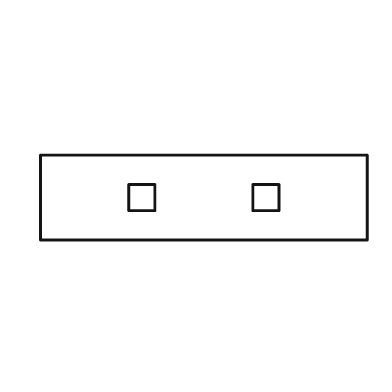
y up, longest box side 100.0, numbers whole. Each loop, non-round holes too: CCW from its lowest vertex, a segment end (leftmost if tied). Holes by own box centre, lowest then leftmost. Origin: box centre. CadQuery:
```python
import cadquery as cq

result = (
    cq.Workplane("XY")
    .moveTo(-50.0, -13.0)
    .lineTo(50.0, -13.0)
    .lineTo(50.0, 13.0)
    .lineTo(-50.0, 13.0)
    .close()
    .moveTo(-23.0, -4.0)
    .lineTo(-15.0, -4.0)
    .lineTo(-15.0, 4.0)
    .lineTo(-23.0, 4.0)
    .close()
    .moveTo(15.0, -4.0)
    .lineTo(23.0, -4.0)
    .lineTo(23.0, 4.0)
    .lineTo(15.0, 4.0)
    .close()
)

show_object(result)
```